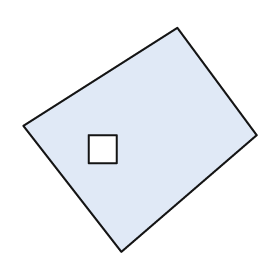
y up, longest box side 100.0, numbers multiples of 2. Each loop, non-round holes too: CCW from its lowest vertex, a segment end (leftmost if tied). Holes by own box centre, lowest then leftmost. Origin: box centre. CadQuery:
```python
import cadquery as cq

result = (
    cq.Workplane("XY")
    .moveTo(-8.0, -48.0)
    .lineTo(50.0, 2.0)
    .lineTo(16.0, 48.0)
    .lineTo(-50.0, 6.0)
    .close()
    .moveTo(-22.0, -10.0)
    .lineTo(-10.0, -10.0)
    .lineTo(-10.0, 2.0)
    .lineTo(-22.0, 2.0)
    .close()
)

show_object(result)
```